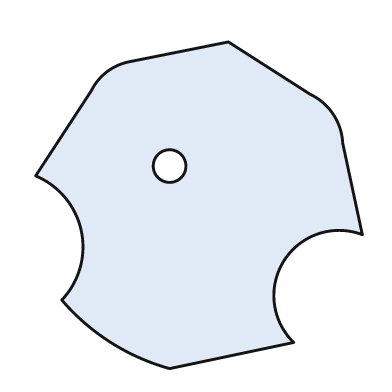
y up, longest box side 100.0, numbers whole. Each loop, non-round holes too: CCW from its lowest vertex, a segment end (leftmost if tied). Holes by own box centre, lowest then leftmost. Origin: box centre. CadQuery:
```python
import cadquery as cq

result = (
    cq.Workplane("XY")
    .moveTo(-9.0, -50.0)
    .lineTo(29.0, -42.0)
    .threePointArc((26.0, -17.0), (50.0, -9.0))
    .lineTo(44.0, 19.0)
    .threePointArc((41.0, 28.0), (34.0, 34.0))
    .lineTo(9.0, 50.0)
    .lineTo(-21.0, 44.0)
    .threePointArc((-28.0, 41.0), (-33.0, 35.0))
    .lineTo(-50.0, 9.0)
    .threePointArc((-36.0, -8.0), (-42.0, -29.0))
    .threePointArc((-27.0, -42.0), (-9.0, -50.0))
    .close()
    .moveTo(-9.0, 12.0)
    .circle(5.0)
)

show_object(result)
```